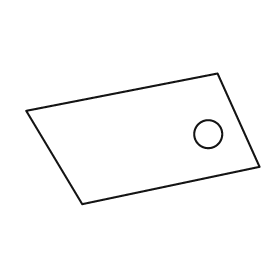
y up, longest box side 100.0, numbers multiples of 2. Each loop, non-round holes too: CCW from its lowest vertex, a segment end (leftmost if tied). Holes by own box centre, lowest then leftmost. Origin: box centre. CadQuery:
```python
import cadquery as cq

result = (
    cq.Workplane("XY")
    .moveTo(-26.0, -28.0)
    .lineTo(50.0, -12.0)
    .lineTo(32.0, 28.0)
    .lineTo(-50.0, 12.0)
    .close()
    .moveTo(28.0, 2.0)
    .circle(6.0)
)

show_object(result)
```